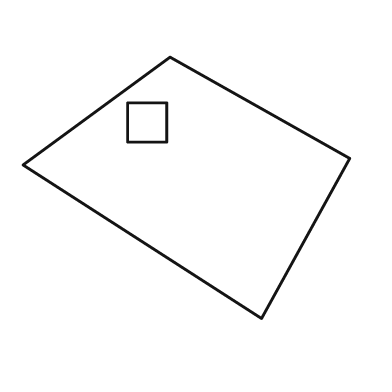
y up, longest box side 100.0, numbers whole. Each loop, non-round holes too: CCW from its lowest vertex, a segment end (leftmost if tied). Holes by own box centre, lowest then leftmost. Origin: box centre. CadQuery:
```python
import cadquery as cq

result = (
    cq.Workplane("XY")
    .moveTo(23.0, -40.0)
    .lineTo(50.0, 9.0)
    .lineTo(-5.0, 40.0)
    .lineTo(-50.0, 7.0)
    .close()
    .moveTo(-18.0, 14.0)
    .lineTo(-6.0, 14.0)
    .lineTo(-6.0, 26.0)
    .lineTo(-18.0, 26.0)
    .close()
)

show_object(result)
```